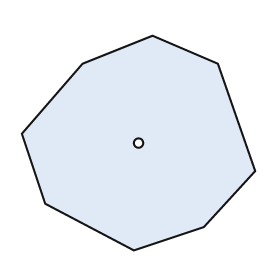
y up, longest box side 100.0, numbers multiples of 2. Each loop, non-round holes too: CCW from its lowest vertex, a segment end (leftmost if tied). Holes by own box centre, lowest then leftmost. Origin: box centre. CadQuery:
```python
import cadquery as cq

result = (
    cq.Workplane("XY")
    .moveTo(-2.0, -46.0)
    .lineTo(28.0, -36.0)
    .lineTo(50.0, -12.0)
    .lineTo(34.0, 34.0)
    .lineTo(6.0, 46.0)
    .lineTo(-24.0, 34.0)
    .lineTo(-50.0, 4.0)
    .lineTo(-40.0, -26.0)
    .close()
    .moveTo(0.0, 0.0)
    .circle(2.0)
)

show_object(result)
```